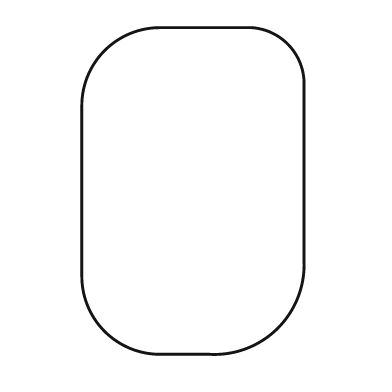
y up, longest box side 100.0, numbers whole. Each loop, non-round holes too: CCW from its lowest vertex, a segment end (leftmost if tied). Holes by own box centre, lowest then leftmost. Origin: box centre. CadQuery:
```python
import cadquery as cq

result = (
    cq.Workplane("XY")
    .moveTo(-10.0, -50.0)
    .lineTo(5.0, -50.0)
    .threePointArc((26.0, -42.0), (34.0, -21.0))
    .lineTo(34.0, 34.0)
    .threePointArc((29.0, 45.0), (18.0, 50.0))
    .lineTo(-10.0, 50.0)
    .threePointArc((-27.0, 43.0), (-34.0, 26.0))
    .lineTo(-34.0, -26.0)
    .threePointArc((-27.0, -43.0), (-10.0, -50.0))
    .close()
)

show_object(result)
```